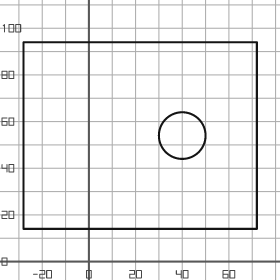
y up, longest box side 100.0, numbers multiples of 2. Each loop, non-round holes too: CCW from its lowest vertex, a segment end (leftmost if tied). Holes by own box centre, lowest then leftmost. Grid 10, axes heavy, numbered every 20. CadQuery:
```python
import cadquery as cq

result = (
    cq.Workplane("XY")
    .moveTo(-28.0, 14.0)
    .lineTo(72.0, 14.0)
    .lineTo(72.0, 94.0)
    .lineTo(-28.0, 94.0)
    .close()
    .moveTo(40.0, 54.0)
    .circle(10.0)
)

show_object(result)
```